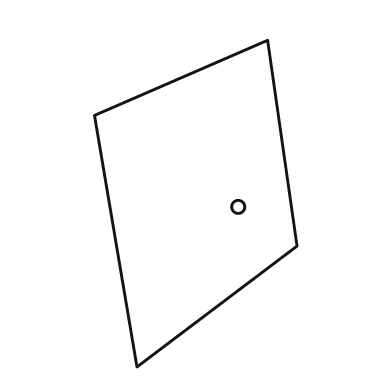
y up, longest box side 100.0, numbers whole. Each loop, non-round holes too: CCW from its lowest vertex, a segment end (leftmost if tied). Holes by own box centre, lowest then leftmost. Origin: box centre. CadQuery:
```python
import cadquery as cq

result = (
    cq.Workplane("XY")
    .moveTo(-18.0, -50.0)
    .lineTo(31.0, -13.0)
    .lineTo(22.0, 50.0)
    .lineTo(-31.0, 27.0)
    .close()
    .moveTo(13.0, -1.0)
    .circle(2.0)
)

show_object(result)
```